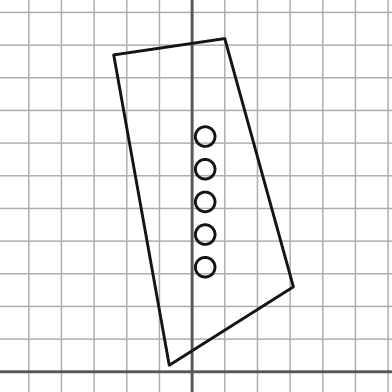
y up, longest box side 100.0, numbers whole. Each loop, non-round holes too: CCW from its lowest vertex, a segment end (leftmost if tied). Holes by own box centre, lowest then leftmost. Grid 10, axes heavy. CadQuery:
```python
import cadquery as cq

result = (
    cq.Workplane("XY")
    .moveTo(-7.0, 2.0)
    .lineTo(31.0, 26.0)
    .lineTo(10.0, 102.0)
    .lineTo(-24.0, 97.0)
    .close()
    .moveTo(4.0, 32.0)
    .circle(3.0)
    .moveTo(4.0, 42.0)
    .circle(3.0)
    .moveTo(4.0, 52.0)
    .circle(3.0)
    .moveTo(4.0, 62.0)
    .circle(3.0)
    .moveTo(4.0, 72.0)
    .circle(3.0)
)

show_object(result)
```